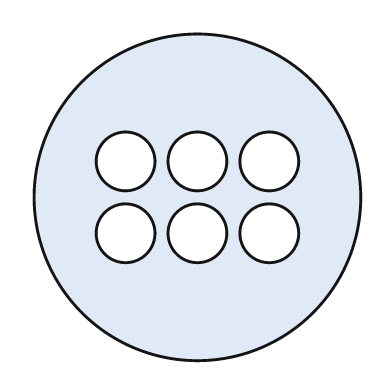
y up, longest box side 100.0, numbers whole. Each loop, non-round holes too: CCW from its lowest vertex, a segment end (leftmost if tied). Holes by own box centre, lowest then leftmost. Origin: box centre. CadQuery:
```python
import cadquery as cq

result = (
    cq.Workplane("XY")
    .moveTo(0.0, 0.0)
    .circle(50.0)
    .moveTo(-22.0, -11.0)
    .circle(9.0)
    .moveTo(0.0, -11.0)
    .circle(9.0)
    .moveTo(22.0, -11.0)
    .circle(9.0)
    .moveTo(-22.0, 11.0)
    .circle(9.0)
    .moveTo(0.0, 11.0)
    .circle(9.0)
    .moveTo(22.0, 11.0)
    .circle(9.0)
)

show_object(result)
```